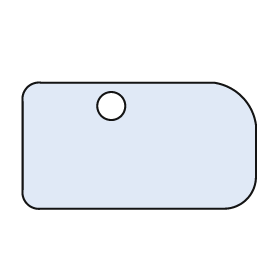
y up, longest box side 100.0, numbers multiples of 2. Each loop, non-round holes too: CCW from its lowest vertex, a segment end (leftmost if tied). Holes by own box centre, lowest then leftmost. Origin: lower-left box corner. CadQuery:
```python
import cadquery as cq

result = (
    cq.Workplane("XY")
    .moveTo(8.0, 0.0)
    .lineTo(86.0, 0.0)
    .threePointArc((96.0, 4.0), (100.0, 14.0))
    .lineTo(100.0, 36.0)
    .threePointArc((94.0, 48.0), (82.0, 54.0))
    .lineTo(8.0, 54.0)
    .threePointArc((2.0, 52.0), (0.0, 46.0))
    .lineTo(0.0, 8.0)
    .threePointArc((2.0, 2.0), (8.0, 0.0))
    .close()
    .moveTo(38.0, 44.0)
    .circle(6.0)
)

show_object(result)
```